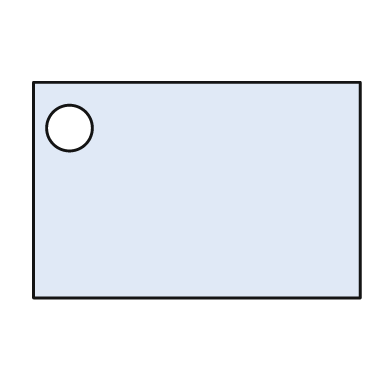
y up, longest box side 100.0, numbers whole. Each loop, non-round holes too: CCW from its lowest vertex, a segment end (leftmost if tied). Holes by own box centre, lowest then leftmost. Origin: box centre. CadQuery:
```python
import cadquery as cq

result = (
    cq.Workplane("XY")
    .moveTo(-50.0, -33.0)
    .lineTo(50.0, -33.0)
    .lineTo(50.0, 33.0)
    .lineTo(-50.0, 33.0)
    .close()
    .moveTo(-39.0, 19.0)
    .circle(7.0)
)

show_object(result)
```